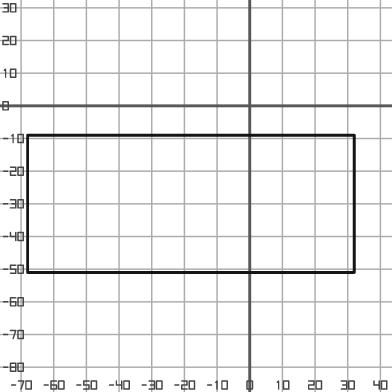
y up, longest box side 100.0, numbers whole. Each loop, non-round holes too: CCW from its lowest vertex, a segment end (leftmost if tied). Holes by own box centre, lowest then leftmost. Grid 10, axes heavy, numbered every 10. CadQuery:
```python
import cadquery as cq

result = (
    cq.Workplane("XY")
    .moveTo(-68.0, -51.0)
    .lineTo(32.0, -51.0)
    .lineTo(32.0, -9.0)
    .lineTo(-68.0, -9.0)
    .close()
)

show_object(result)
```